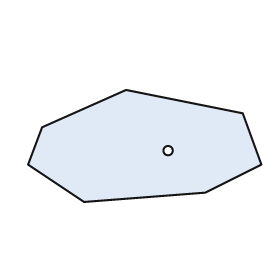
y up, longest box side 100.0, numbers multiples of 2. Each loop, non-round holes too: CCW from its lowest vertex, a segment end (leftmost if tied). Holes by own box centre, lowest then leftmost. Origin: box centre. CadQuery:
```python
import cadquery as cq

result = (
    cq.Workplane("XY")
    .moveTo(-26.0, -24.0)
    .lineTo(26.0, -20.0)
    .lineTo(50.0, -8.0)
    .lineTo(42.0, 14.0)
    .lineTo(-8.0, 24.0)
    .lineTo(-44.0, 8.0)
    .lineTo(-50.0, -8.0)
    .close()
    .moveTo(10.0, -2.0)
    .circle(2.0)
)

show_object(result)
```